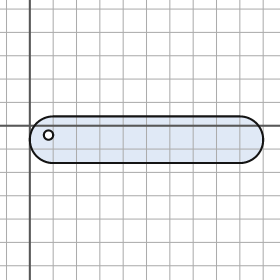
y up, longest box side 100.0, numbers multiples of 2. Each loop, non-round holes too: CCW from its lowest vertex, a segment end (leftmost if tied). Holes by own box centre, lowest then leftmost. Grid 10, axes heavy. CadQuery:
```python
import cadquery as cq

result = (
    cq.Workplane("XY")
    .moveTo(10.0, -16.0)
    .lineTo(90.0, -16.0)
    .threePointArc((100.0, -6.0), (90.0, 4.0))
    .lineTo(10.0, 4.0)
    .threePointArc((0.0, -6.0), (10.0, -16.0))
    .close()
    .moveTo(8.0, -4.0)
    .circle(2.0)
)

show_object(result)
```